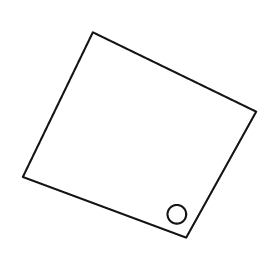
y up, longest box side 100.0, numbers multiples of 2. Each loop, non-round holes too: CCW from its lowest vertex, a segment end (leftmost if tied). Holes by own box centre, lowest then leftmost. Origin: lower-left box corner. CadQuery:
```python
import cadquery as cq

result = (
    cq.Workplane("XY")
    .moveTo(70.0, 0.0)
    .lineTo(100.0, 54.0)
    .lineTo(30.0, 88.0)
    .lineTo(0.0, 26.0)
    .close()
    .moveTo(66.0, 10.0)
    .circle(4.0)
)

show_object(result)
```